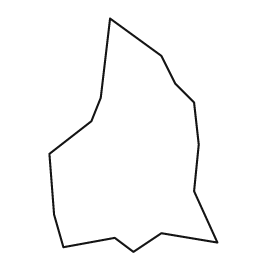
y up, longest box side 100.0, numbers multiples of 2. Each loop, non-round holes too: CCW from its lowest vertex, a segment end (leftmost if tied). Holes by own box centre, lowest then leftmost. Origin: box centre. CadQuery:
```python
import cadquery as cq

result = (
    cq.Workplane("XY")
    .moveTo(0.0, -50.0)
    .lineTo(12.0, -42.0)
    .lineTo(36.0, -46.0)
    .lineTo(26.0, -24.0)
    .lineTo(28.0, -4.0)
    .lineTo(26.0, 14.0)
    .lineTo(18.0, 22.0)
    .lineTo(12.0, 34.0)
    .lineTo(-10.0, 50.0)
    .lineTo(-14.0, 16.0)
    .lineTo(-18.0, 6.0)
    .lineTo(-36.0, -8.0)
    .lineTo(-34.0, -34.0)
    .lineTo(-30.0, -48.0)
    .lineTo(-8.0, -44.0)
    .close()
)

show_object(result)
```